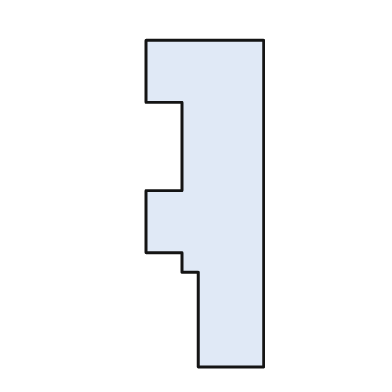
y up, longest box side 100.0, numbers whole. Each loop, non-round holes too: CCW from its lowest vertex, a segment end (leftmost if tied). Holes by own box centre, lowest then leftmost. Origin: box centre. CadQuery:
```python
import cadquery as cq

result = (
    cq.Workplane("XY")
    .moveTo(-2.0, -50.0)
    .lineTo(18.0, -50.0)
    .lineTo(18.0, 50.0)
    .lineTo(-18.0, 50.0)
    .lineTo(-18.0, 31.0)
    .lineTo(-7.0, 31.0)
    .lineTo(-7.0, 4.0)
    .lineTo(-18.0, 4.0)
    .lineTo(-18.0, -15.0)
    .lineTo(-7.0, -15.0)
    .lineTo(-7.0, -21.0)
    .lineTo(-2.0, -21.0)
    .close()
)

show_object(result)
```